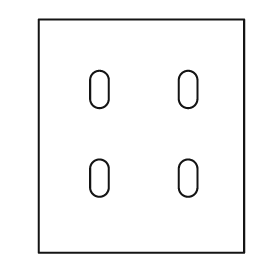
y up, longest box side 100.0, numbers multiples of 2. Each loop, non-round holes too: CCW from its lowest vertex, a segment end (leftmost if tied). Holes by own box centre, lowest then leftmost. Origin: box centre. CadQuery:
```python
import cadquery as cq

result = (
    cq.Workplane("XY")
    .moveTo(-44.0, -50.0)
    .lineTo(44.0, -50.0)
    .lineTo(44.0, 50.0)
    .lineTo(-44.0, 50.0)
    .close()
    .moveTo(-22.0, -22.0)
    .threePointArc((-18.0, -26.0), (-14.0, -22.0))
    .lineTo(-14.0, -14.0)
    .threePointArc((-18.0, -10.0), (-22.0, -14.0))
    .close()
    .moveTo(16.0, -22.0)
    .threePointArc((20.0, -26.0), (24.0, -22.0))
    .lineTo(24.0, -14.0)
    .threePointArc((20.0, -10.0), (16.0, -14.0))
    .close()
    .moveTo(-22.0, 16.0)
    .threePointArc((-18.0, 12.0), (-14.0, 16.0))
    .lineTo(-14.0, 24.0)
    .threePointArc((-18.0, 28.0), (-22.0, 24.0))
    .close()
    .moveTo(16.0, 16.0)
    .threePointArc((20.0, 12.0), (24.0, 16.0))
    .lineTo(24.0, 24.0)
    .threePointArc((20.0, 28.0), (16.0, 24.0))
    .close()
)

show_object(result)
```